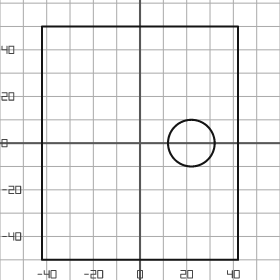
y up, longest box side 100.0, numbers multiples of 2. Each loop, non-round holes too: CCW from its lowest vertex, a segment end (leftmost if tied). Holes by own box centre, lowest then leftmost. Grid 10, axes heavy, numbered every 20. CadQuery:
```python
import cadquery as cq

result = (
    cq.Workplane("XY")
    .moveTo(-42.0, -50.0)
    .lineTo(42.0, -50.0)
    .lineTo(42.0, 50.0)
    .lineTo(-42.0, 50.0)
    .close()
    .moveTo(22.0, 0.0)
    .circle(10.0)
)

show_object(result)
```